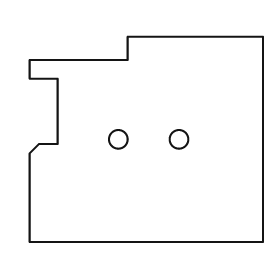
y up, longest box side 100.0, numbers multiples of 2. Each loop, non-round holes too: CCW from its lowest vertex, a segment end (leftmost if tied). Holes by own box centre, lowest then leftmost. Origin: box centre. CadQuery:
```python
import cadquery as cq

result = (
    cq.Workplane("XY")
    .moveTo(-50.0, -44.0)
    .lineTo(50.0, -44.0)
    .lineTo(50.0, 44.0)
    .lineTo(-8.0, 44.0)
    .lineTo(-8.0, 34.0)
    .lineTo(-50.0, 34.0)
    .lineTo(-50.0, 26.0)
    .lineTo(-38.0, 26.0)
    .lineTo(-38.0, -2.0)
    .lineTo(-46.0, -2.0)
    .lineTo(-50.0, -6.0)
    .close()
    .moveTo(-12.0, 0.0)
    .circle(4.0)
    .moveTo(14.0, 0.0)
    .circle(4.0)
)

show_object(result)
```